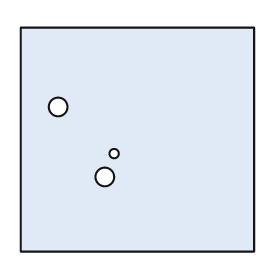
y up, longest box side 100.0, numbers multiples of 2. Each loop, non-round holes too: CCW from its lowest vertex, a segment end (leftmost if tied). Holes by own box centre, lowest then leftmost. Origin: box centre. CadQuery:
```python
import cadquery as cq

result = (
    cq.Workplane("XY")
    .moveTo(-50.0, -48.0)
    .lineTo(50.0, -48.0)
    .lineTo(50.0, 48.0)
    .lineTo(-50.0, 48.0)
    .close()
    .moveTo(-14.0, -16.0)
    .circle(4.0)
    .moveTo(-10.0, -6.0)
    .circle(2.0)
    .moveTo(-34.0, 14.0)
    .circle(4.0)
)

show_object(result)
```